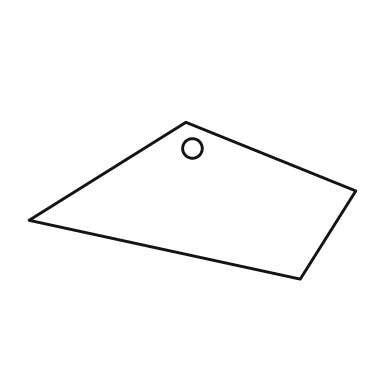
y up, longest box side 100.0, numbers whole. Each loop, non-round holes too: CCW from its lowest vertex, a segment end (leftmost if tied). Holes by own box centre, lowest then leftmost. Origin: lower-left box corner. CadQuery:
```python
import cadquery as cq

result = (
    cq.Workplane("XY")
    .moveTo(83.0, 0.0)
    .lineTo(100.0, 27.0)
    .lineTo(48.0, 48.0)
    .lineTo(0.0, 18.0)
    .close()
    .moveTo(50.0, 40.0)
    .circle(3.0)
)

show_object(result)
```